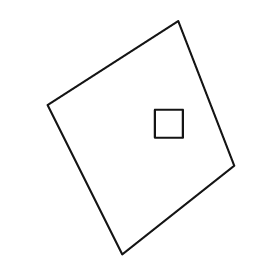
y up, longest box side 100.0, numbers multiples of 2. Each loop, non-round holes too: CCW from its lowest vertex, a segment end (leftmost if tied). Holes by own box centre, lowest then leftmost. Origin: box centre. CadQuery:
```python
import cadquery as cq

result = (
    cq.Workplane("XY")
    .moveTo(-8.0, -50.0)
    .lineTo(40.0, -12.0)
    .lineTo(16.0, 50.0)
    .lineTo(-40.0, 14.0)
    .close()
    .moveTo(6.0, 0.0)
    .lineTo(18.0, 0.0)
    .lineTo(18.0, 12.0)
    .lineTo(6.0, 12.0)
    .close()
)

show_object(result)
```